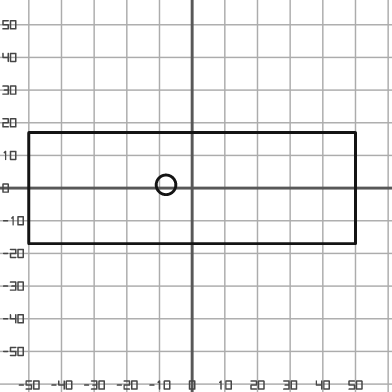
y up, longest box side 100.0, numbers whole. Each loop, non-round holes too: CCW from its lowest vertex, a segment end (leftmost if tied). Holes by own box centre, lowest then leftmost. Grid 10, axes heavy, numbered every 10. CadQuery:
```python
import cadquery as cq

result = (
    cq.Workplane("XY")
    .moveTo(-50.0, -17.0)
    .lineTo(50.0, -17.0)
    .lineTo(50.0, 17.0)
    .lineTo(-50.0, 17.0)
    .close()
    .moveTo(-8.0, 1.0)
    .circle(3.0)
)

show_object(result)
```